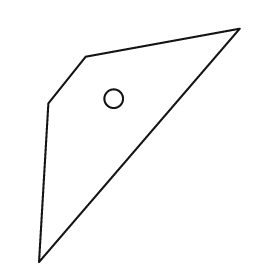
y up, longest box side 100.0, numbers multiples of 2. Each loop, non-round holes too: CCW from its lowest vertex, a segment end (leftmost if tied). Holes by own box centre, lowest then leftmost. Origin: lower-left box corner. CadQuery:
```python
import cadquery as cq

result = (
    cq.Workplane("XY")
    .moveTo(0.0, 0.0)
    .lineTo(86.0, 100.0)
    .lineTo(20.0, 88.0)
    .lineTo(4.0, 68.0)
    .close()
    .moveTo(32.0, 70.0)
    .circle(4.0)
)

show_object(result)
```